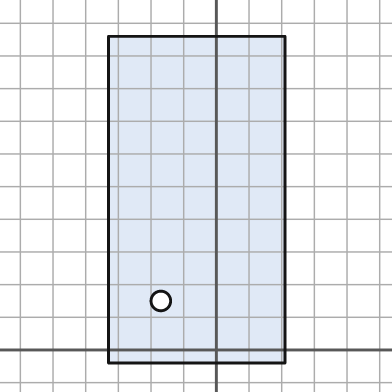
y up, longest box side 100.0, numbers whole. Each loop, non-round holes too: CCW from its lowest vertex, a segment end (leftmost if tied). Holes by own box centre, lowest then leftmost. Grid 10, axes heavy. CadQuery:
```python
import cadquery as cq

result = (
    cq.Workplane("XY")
    .moveTo(-33.0, -4.0)
    .lineTo(21.0, -4.0)
    .lineTo(21.0, 96.0)
    .lineTo(-33.0, 96.0)
    .close()
    .moveTo(-17.0, 15.0)
    .circle(3.0)
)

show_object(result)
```